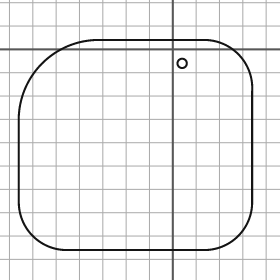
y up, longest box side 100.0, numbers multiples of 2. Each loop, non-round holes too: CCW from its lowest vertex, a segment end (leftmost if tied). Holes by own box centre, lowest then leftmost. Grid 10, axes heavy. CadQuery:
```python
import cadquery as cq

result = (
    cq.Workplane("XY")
    .moveTo(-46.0, -86.0)
    .lineTo(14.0, -86.0)
    .threePointArc((28.0, -80.0), (34.0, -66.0))
    .lineTo(34.0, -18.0)
    .threePointArc((28.0, -2.0), (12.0, 4.0))
    .lineTo(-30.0, 4.0)
    .threePointArc((-56.0, -6.0), (-66.0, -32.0))
    .lineTo(-66.0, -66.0)
    .threePointArc((-60.0, -80.0), (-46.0, -86.0))
    .close()
    .moveTo(4.0, -6.0)
    .circle(2.0)
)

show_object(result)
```